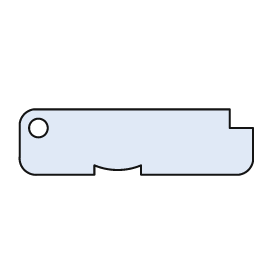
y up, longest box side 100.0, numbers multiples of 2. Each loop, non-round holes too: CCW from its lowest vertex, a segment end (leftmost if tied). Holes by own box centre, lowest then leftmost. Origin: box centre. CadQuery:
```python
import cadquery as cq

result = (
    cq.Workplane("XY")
    .moveTo(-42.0, -14.0)
    .lineTo(-18.0, -14.0)
    .lineTo(-18.0, -10.0)
    .threePointArc((-8.0, -12.0), (2.0, -10.0))
    .lineTo(2.0, -14.0)
    .lineTo(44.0, -14.0)
    .threePointArc((48.0, -12.0), (50.0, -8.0))
    .lineTo(50.0, 6.0)
    .lineTo(40.0, 6.0)
    .lineTo(40.0, 14.0)
    .lineTo(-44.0, 14.0)
    .threePointArc((-48.0, 12.0), (-50.0, 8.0))
    .lineTo(-50.0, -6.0)
    .threePointArc((-48.0, -12.0), (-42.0, -14.0))
    .close()
    .moveTo(-42.0, 6.0)
    .circle(4.0)
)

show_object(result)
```